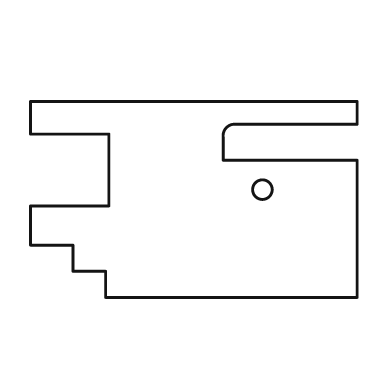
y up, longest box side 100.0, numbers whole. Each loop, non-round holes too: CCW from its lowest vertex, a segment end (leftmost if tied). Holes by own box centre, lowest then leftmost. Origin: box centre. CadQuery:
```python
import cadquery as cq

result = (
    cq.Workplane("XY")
    .moveTo(-27.0, -30.0)
    .lineTo(50.0, -30.0)
    .lineTo(50.0, 12.0)
    .lineTo(9.0, 12.0)
    .lineTo(9.0, 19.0)
    .threePointArc((10.0, 22.0), (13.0, 23.0))
    .lineTo(50.0, 23.0)
    .lineTo(50.0, 30.0)
    .lineTo(-50.0, 30.0)
    .lineTo(-50.0, 20.0)
    .lineTo(-26.0, 20.0)
    .lineTo(-26.0, -2.0)
    .lineTo(-50.0, -2.0)
    .lineTo(-50.0, -14.0)
    .lineTo(-37.0, -14.0)
    .lineTo(-37.0, -22.0)
    .lineTo(-27.0, -22.0)
    .close()
    .moveTo(21.0, 3.0)
    .circle(3.0)
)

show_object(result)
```